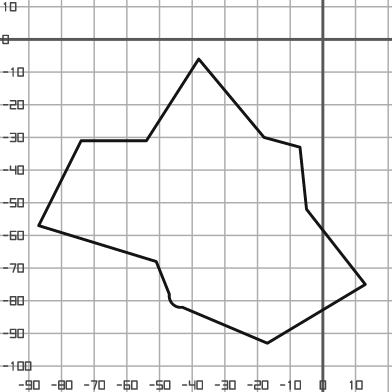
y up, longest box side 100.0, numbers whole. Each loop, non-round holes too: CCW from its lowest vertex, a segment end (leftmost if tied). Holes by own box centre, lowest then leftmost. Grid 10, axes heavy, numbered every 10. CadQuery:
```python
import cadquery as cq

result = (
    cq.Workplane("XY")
    .moveTo(-17.0, -93.0)
    .lineTo(13.0, -75.0)
    .lineTo(-5.0, -52.0)
    .lineTo(-7.0, -33.0)
    .lineTo(-18.0, -30.0)
    .lineTo(-38.0, -6.0)
    .lineTo(-54.0, -31.0)
    .lineTo(-74.0, -31.0)
    .lineTo(-87.0, -57.0)
    .lineTo(-51.0, -68.0)
    .lineTo(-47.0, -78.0)
    .threePointArc((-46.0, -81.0), (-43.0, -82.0))
    .close()
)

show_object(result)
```